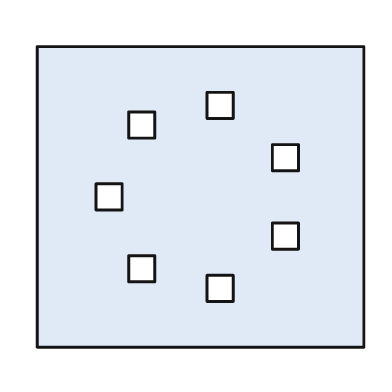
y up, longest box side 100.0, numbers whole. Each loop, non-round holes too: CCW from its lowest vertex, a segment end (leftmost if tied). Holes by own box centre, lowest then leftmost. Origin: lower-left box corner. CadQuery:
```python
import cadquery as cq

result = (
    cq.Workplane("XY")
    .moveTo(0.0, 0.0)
    .lineTo(100.0, 0.0)
    .lineTo(100.0, 92.0)
    .lineTo(0.0, 92.0)
    .close()
    .moveTo(52.0, 14.0)
    .lineTo(60.0, 14.0)
    .lineTo(60.0, 22.0)
    .lineTo(52.0, 22.0)
    .close()
    .moveTo(28.0, 20.0)
    .lineTo(36.0, 20.0)
    .lineTo(36.0, 28.0)
    .lineTo(28.0, 28.0)
    .close()
    .moveTo(72.0, 30.0)
    .lineTo(80.0, 30.0)
    .lineTo(80.0, 38.0)
    .lineTo(72.0, 38.0)
    .close()
    .moveTo(18.0, 42.0)
    .lineTo(26.0, 42.0)
    .lineTo(26.0, 50.0)
    .lineTo(18.0, 50.0)
    .close()
    .moveTo(72.0, 54.0)
    .lineTo(80.0, 54.0)
    .lineTo(80.0, 62.0)
    .lineTo(72.0, 62.0)
    .close()
    .moveTo(28.0, 64.0)
    .lineTo(36.0, 64.0)
    .lineTo(36.0, 72.0)
    .lineTo(28.0, 72.0)
    .close()
    .moveTo(52.0, 70.0)
    .lineTo(60.0, 70.0)
    .lineTo(60.0, 78.0)
    .lineTo(52.0, 78.0)
    .close()
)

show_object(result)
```